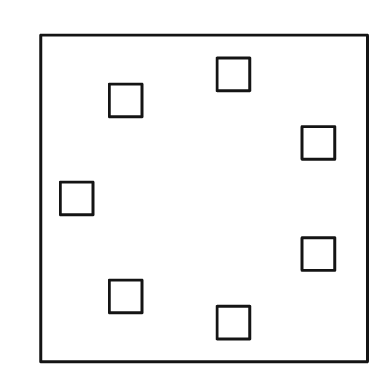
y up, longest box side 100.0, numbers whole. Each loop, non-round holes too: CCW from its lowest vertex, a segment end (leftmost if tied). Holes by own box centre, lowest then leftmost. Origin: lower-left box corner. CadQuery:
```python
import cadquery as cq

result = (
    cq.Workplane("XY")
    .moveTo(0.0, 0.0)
    .lineTo(100.0, 0.0)
    .lineTo(100.0, 100.0)
    .lineTo(0.0, 100.0)
    .close()
    .moveTo(54.0, 7.0)
    .lineTo(64.0, 7.0)
    .lineTo(64.0, 17.0)
    .lineTo(54.0, 17.0)
    .close()
    .moveTo(21.0, 15.0)
    .lineTo(31.0, 15.0)
    .lineTo(31.0, 25.0)
    .lineTo(21.0, 25.0)
    .close()
    .moveTo(80.0, 28.0)
    .lineTo(90.0, 28.0)
    .lineTo(90.0, 38.0)
    .lineTo(80.0, 38.0)
    .close()
    .moveTo(6.0, 45.0)
    .lineTo(16.0, 45.0)
    .lineTo(16.0, 55.0)
    .lineTo(6.0, 55.0)
    .close()
    .moveTo(80.0, 62.0)
    .lineTo(90.0, 62.0)
    .lineTo(90.0, 72.0)
    .lineTo(80.0, 72.0)
    .close()
    .moveTo(21.0, 75.0)
    .lineTo(31.0, 75.0)
    .lineTo(31.0, 85.0)
    .lineTo(21.0, 85.0)
    .close()
    .moveTo(54.0, 83.0)
    .lineTo(64.0, 83.0)
    .lineTo(64.0, 93.0)
    .lineTo(54.0, 93.0)
    .close()
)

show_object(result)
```